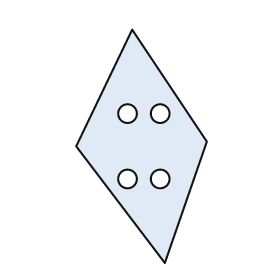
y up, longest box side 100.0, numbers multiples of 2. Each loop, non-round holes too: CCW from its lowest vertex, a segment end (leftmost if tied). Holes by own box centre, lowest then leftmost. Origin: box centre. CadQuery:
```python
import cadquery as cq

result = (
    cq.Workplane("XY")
    .moveTo(10.0, -50.0)
    .lineTo(28.0, 2.0)
    .lineTo(-4.0, 50.0)
    .lineTo(-28.0, 0.0)
    .close()
    .moveTo(-6.0, -14.0)
    .circle(4.0)
    .moveTo(8.0, -14.0)
    .circle(4.0)
    .moveTo(-6.0, 14.0)
    .circle(4.0)
    .moveTo(8.0, 14.0)
    .circle(4.0)
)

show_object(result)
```